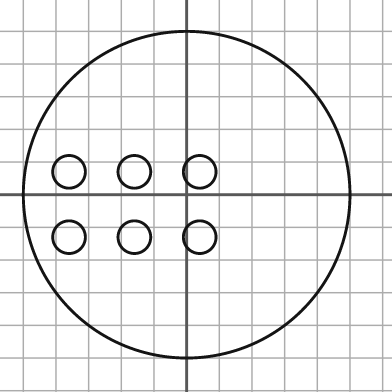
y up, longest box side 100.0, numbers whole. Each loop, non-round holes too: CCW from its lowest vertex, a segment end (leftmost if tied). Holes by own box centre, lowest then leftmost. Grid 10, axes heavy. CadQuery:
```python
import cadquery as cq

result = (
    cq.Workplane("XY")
    .moveTo(0.0, 0.0)
    .circle(50.0)
    .moveTo(-36.0, -13.0)
    .circle(5.0)
    .moveTo(-16.0, -13.0)
    .circle(5.0)
    .moveTo(4.0, -13.0)
    .circle(5.0)
    .moveTo(-36.0, 7.0)
    .circle(5.0)
    .moveTo(-16.0, 7.0)
    .circle(5.0)
    .moveTo(4.0, 7.0)
    .circle(5.0)
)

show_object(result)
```